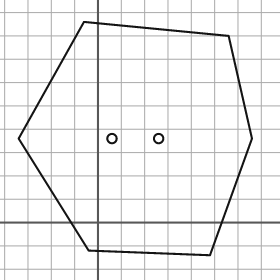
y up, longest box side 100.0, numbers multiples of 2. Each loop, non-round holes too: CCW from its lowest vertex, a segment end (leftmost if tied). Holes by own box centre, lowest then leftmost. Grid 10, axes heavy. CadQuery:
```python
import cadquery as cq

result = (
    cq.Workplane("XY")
    .moveTo(48.0, -14.0)
    .lineTo(66.0, 36.0)
    .lineTo(56.0, 80.0)
    .lineTo(-6.0, 86.0)
    .lineTo(-34.0, 36.0)
    .lineTo(-4.0, -12.0)
    .close()
    .moveTo(6.0, 36.0)
    .circle(2.0)
    .moveTo(26.0, 36.0)
    .circle(2.0)
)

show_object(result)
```